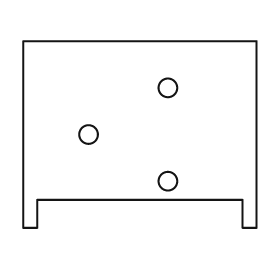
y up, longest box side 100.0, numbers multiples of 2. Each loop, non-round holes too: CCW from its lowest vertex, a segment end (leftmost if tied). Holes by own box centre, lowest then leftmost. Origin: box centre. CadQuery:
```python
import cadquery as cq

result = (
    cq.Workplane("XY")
    .moveTo(-50.0, -40.0)
    .lineTo(-44.0, -40.0)
    .lineTo(-44.0, -28.0)
    .lineTo(44.0, -28.0)
    .lineTo(44.0, -40.0)
    .lineTo(50.0, -40.0)
    .lineTo(50.0, 40.0)
    .lineTo(-50.0, 40.0)
    .close()
    .moveTo(12.0, -20.0)
    .circle(4.0)
    .moveTo(-22.0, 0.0)
    .circle(4.0)
    .moveTo(12.0, 20.0)
    .circle(4.0)
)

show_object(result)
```